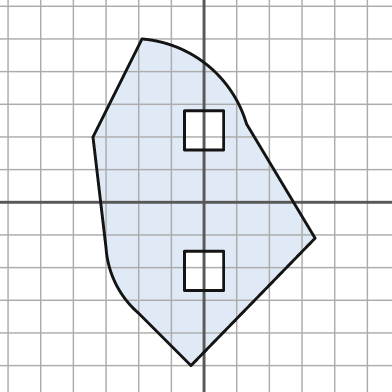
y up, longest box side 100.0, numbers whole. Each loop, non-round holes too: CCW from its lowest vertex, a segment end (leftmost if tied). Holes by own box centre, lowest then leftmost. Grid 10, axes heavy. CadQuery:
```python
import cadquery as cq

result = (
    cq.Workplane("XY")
    .moveTo(-4.0, -50.0)
    .lineTo(34.0, -11.0)
    .lineTo(13.0, 24.0)
    .threePointArc((1.0, 42.0), (-19.0, 50.0))
    .lineTo(-34.0, 20.0)
    .lineTo(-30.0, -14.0)
    .threePointArc((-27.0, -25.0), (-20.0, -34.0))
    .close()
    .moveTo(-6.0, -27.0)
    .lineTo(6.0, -27.0)
    .lineTo(6.0, -15.0)
    .lineTo(-6.0, -15.0)
    .close()
    .moveTo(-6.0, 16.0)
    .lineTo(6.0, 16.0)
    .lineTo(6.0, 28.0)
    .lineTo(-6.0, 28.0)
    .close()
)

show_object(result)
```